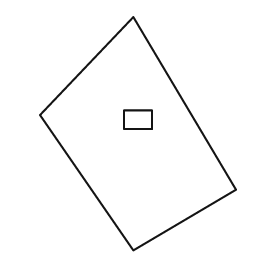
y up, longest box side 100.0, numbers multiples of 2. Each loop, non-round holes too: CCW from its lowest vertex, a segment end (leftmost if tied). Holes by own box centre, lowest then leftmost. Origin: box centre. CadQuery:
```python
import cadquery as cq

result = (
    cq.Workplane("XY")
    .moveTo(-2.0, -50.0)
    .lineTo(42.0, -24.0)
    .lineTo(-2.0, 50.0)
    .lineTo(-42.0, 8.0)
    .close()
    .moveTo(-6.0, 2.0)
    .lineTo(6.0, 2.0)
    .lineTo(6.0, 10.0)
    .lineTo(-6.0, 10.0)
    .close()
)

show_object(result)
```